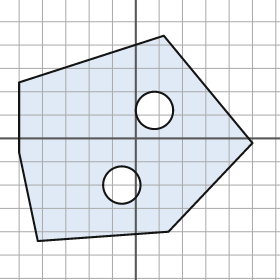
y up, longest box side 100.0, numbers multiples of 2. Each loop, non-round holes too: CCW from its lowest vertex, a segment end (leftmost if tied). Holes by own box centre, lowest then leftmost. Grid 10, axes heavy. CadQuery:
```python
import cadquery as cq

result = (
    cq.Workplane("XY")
    .moveTo(-42.0, -44.0)
    .lineTo(14.0, -40.0)
    .lineTo(50.0, -2.0)
    .lineTo(12.0, 44.0)
    .lineTo(-50.0, 24.0)
    .lineTo(-50.0, -6.0)
    .close()
    .moveTo(-6.0, -20.0)
    .circle(8.0)
    .moveTo(8.0, 12.0)
    .circle(8.0)
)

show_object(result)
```